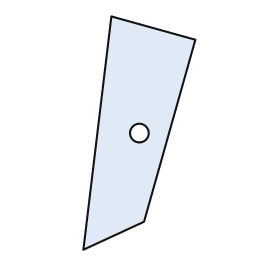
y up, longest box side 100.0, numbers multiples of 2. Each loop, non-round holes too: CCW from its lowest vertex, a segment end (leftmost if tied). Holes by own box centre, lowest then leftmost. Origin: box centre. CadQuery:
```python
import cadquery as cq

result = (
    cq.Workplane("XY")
    .moveTo(-24.0, -50.0)
    .lineTo(2.0, -38.0)
    .lineTo(24.0, 40.0)
    .lineTo(-12.0, 50.0)
    .close()
    .moveTo(0.0, 0.0)
    .circle(4.0)
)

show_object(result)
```